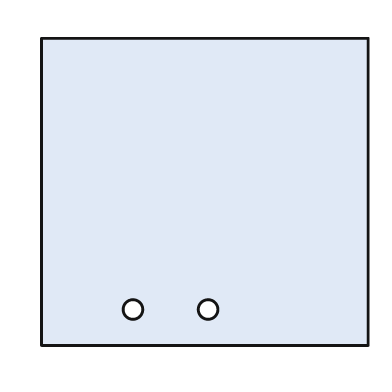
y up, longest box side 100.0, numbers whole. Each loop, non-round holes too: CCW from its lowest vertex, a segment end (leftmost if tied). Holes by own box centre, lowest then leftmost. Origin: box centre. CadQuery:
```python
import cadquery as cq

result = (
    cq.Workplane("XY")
    .moveTo(-50.0, -47.0)
    .lineTo(50.0, -47.0)
    .lineTo(50.0, 47.0)
    .lineTo(-50.0, 47.0)
    .close()
    .moveTo(-22.0, -36.0)
    .circle(3.0)
    .moveTo(1.0, -36.0)
    .circle(3.0)
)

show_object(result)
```